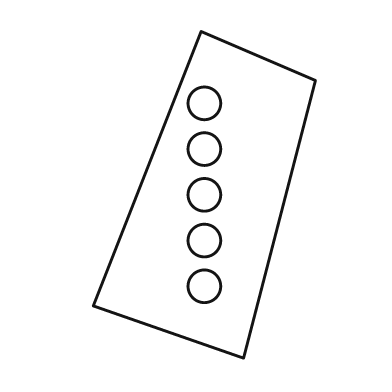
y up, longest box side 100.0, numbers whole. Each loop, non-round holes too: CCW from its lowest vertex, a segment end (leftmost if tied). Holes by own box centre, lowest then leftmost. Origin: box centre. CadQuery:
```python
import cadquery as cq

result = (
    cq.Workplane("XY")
    .moveTo(12.0, -50.0)
    .lineTo(34.0, 35.0)
    .lineTo(-1.0, 50.0)
    .lineTo(-34.0, -34.0)
    .close()
    .moveTo(0.0, -28.0)
    .circle(5.0)
    .moveTo(0.0, -14.0)
    .circle(5.0)
    .moveTo(0.0, 0.0)
    .circle(5.0)
    .moveTo(0.0, 14.0)
    .circle(5.0)
    .moveTo(0.0, 28.0)
    .circle(5.0)
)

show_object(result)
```